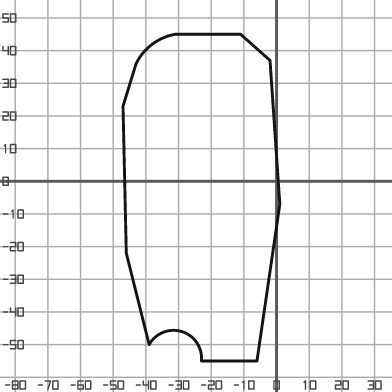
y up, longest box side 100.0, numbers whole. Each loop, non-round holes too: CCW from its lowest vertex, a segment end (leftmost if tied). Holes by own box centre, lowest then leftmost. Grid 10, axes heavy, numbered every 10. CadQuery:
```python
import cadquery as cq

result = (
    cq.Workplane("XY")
    .moveTo(-23.0, -55.0)
    .lineTo(-6.0, -55.0)
    .lineTo(1.0, -7.0)
    .lineTo(-2.0, 37.0)
    .lineTo(-11.0, 45.0)
    .lineTo(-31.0, 45.0)
    .threePointArc((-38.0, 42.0), (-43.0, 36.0))
    .lineTo(-47.0, 23.0)
    .lineTo(-46.0, -22.0)
    .lineTo(-39.0, -50.0)
    .threePointArc((-29.0, -46.0), (-23.0, -55.0))
    .close()
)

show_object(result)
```